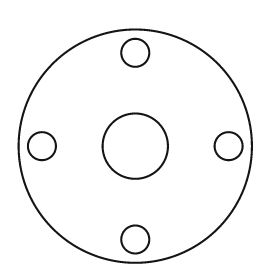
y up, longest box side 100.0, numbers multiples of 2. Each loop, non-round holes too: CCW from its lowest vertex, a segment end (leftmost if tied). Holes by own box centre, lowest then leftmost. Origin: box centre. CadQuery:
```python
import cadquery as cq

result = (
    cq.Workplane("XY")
    .moveTo(0.0, 0.0)
    .circle(50.0)
    .moveTo(0.0, -40.0)
    .circle(6.0)
    .moveTo(-40.0, 0.0)
    .circle(6.0)
    .moveTo(0.0, 0.0)
    .circle(14.0)
    .moveTo(40.0, 0.0)
    .circle(6.0)
    .moveTo(0.0, 40.0)
    .circle(6.0)
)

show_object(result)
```